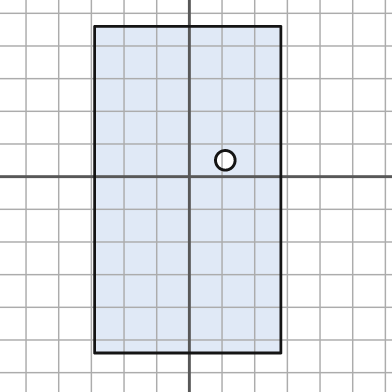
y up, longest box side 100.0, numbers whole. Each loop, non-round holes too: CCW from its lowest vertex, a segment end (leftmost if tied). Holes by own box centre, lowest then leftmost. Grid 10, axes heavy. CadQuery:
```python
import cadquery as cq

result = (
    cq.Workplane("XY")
    .moveTo(-29.0, -54.0)
    .lineTo(28.0, -54.0)
    .lineTo(28.0, 46.0)
    .lineTo(-29.0, 46.0)
    .close()
    .moveTo(11.0, 5.0)
    .circle(3.0)
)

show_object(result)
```